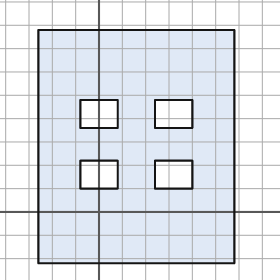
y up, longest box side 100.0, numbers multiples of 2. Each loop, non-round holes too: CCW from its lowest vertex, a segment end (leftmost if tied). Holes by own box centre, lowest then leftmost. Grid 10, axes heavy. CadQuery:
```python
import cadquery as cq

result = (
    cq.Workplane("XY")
    .moveTo(-26.0, -22.0)
    .lineTo(58.0, -22.0)
    .lineTo(58.0, 78.0)
    .lineTo(-26.0, 78.0)
    .close()
    .moveTo(-8.0, 10.0)
    .lineTo(8.0, 10.0)
    .lineTo(8.0, 22.0)
    .lineTo(-8.0, 22.0)
    .close()
    .moveTo(24.0, 10.0)
    .lineTo(40.0, 10.0)
    .lineTo(40.0, 22.0)
    .lineTo(24.0, 22.0)
    .close()
    .moveTo(-8.0, 36.0)
    .lineTo(8.0, 36.0)
    .lineTo(8.0, 48.0)
    .lineTo(-8.0, 48.0)
    .close()
    .moveTo(24.0, 36.0)
    .lineTo(40.0, 36.0)
    .lineTo(40.0, 48.0)
    .lineTo(24.0, 48.0)
    .close()
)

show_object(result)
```